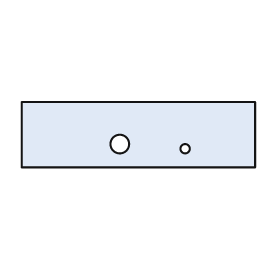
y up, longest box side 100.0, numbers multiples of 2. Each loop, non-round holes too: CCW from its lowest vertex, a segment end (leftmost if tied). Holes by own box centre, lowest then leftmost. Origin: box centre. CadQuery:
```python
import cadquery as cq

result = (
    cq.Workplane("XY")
    .moveTo(-50.0, -14.0)
    .lineTo(50.0, -14.0)
    .lineTo(50.0, 14.0)
    .lineTo(-50.0, 14.0)
    .close()
    .moveTo(20.0, -6.0)
    .circle(2.0)
    .moveTo(-8.0, -4.0)
    .circle(4.0)
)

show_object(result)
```